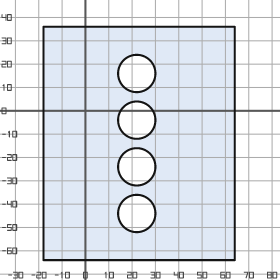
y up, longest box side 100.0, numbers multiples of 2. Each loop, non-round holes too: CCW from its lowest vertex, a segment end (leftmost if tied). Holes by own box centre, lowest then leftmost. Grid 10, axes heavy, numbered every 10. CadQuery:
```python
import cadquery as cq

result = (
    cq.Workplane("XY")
    .moveTo(-18.0, -64.0)
    .lineTo(64.0, -64.0)
    .lineTo(64.0, 36.0)
    .lineTo(-18.0, 36.0)
    .close()
    .moveTo(22.0, -44.0)
    .circle(8.0)
    .moveTo(22.0, -24.0)
    .circle(8.0)
    .moveTo(22.0, -4.0)
    .circle(8.0)
    .moveTo(22.0, 16.0)
    .circle(8.0)
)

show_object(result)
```